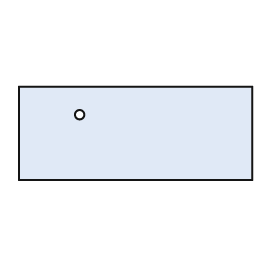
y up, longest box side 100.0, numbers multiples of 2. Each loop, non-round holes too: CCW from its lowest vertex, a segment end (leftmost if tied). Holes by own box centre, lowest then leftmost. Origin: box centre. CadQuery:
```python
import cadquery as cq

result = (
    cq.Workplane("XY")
    .moveTo(-50.0, -20.0)
    .lineTo(50.0, -20.0)
    .lineTo(50.0, 20.0)
    .lineTo(-50.0, 20.0)
    .close()
    .moveTo(-24.0, 8.0)
    .circle(2.0)
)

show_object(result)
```